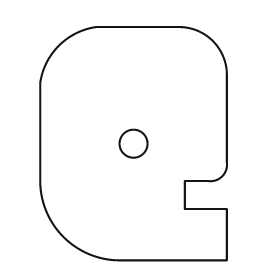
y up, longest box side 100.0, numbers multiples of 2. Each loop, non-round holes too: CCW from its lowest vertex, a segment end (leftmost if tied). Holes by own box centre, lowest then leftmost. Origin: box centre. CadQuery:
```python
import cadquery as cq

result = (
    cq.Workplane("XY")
    .moveTo(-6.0, -50.0)
    .lineTo(40.0, -50.0)
    .lineTo(40.0, -28.0)
    .lineTo(22.0, -28.0)
    .lineTo(22.0, -16.0)
    .lineTo(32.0, -16.0)
    .threePointArc((38.0, -14.0), (40.0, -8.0))
    .lineTo(40.0, 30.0)
    .threePointArc((34.0, 44.0), (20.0, 50.0))
    .lineTo(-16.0, 50.0)
    .threePointArc((-32.0, 42.0), (-40.0, 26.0))
    .lineTo(-40.0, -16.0)
    .threePointArc((-30.0, -40.0), (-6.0, -50.0))
    .close()
    .moveTo(0.0, 0.0)
    .circle(6.0)
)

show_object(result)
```